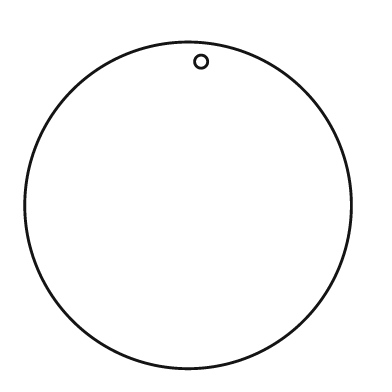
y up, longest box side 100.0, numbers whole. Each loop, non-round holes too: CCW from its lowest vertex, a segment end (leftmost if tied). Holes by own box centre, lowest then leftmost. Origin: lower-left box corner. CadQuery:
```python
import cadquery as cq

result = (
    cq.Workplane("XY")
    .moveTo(50.0, 50.0)
    .circle(50.0)
    .moveTo(54.0, 94.0)
    .circle(2.0)
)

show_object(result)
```